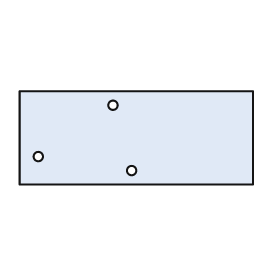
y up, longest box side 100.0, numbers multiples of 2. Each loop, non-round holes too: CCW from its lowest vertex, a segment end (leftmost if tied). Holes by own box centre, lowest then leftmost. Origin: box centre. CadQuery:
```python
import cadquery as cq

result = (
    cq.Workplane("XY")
    .moveTo(-50.0, -20.0)
    .lineTo(50.0, -20.0)
    .lineTo(50.0, 20.0)
    .lineTo(-50.0, 20.0)
    .close()
    .moveTo(-2.0, -14.0)
    .circle(2.0)
    .moveTo(-42.0, -8.0)
    .circle(2.0)
    .moveTo(-10.0, 14.0)
    .circle(2.0)
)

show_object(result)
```